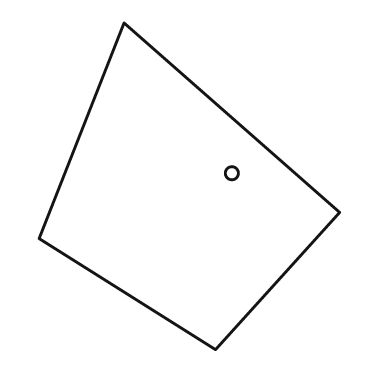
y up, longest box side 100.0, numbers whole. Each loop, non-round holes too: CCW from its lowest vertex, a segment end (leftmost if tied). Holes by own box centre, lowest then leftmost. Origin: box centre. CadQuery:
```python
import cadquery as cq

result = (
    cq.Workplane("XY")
    .moveTo(8.0, -50.0)
    .lineTo(46.0, -8.0)
    .lineTo(-20.0, 50.0)
    .lineTo(-46.0, -16.0)
    .close()
    .moveTo(13.0, 4.0)
    .circle(2.0)
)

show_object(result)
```